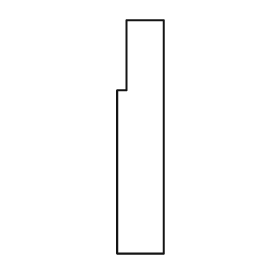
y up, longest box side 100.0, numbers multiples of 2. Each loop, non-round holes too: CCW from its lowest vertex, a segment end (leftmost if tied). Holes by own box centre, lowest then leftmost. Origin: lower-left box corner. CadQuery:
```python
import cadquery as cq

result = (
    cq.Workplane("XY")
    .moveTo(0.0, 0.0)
    .lineTo(20.0, 0.0)
    .lineTo(20.0, 100.0)
    .lineTo(4.0, 100.0)
    .lineTo(4.0, 70.0)
    .lineTo(0.0, 70.0)
    .close()
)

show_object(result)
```